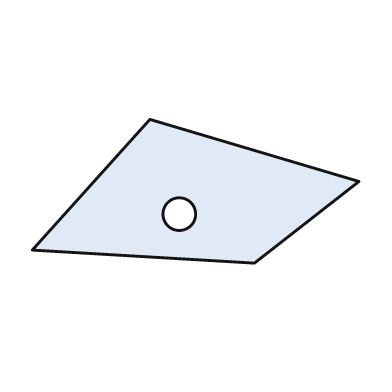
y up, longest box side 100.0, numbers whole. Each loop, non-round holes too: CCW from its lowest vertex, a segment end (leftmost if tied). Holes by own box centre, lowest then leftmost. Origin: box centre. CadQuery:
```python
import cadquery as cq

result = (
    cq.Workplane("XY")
    .moveTo(18.0, -22.0)
    .lineTo(50.0, 3.0)
    .lineTo(-14.0, 22.0)
    .lineTo(-50.0, -18.0)
    .close()
    .moveTo(-5.0, -7.0)
    .circle(5.0)
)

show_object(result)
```